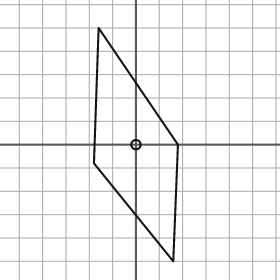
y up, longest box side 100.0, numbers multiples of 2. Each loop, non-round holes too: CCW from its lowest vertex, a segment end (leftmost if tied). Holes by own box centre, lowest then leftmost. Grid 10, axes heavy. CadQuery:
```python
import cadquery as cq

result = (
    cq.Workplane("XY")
    .moveTo(16.0, -50.0)
    .lineTo(18.0, 0.0)
    .lineTo(-16.0, 50.0)
    .lineTo(-18.0, -8.0)
    .close()
    .moveTo(0.0, 0.0)
    .circle(2.0)
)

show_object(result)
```